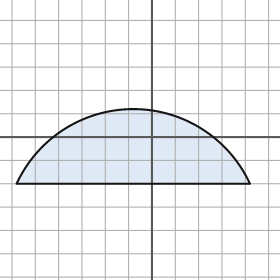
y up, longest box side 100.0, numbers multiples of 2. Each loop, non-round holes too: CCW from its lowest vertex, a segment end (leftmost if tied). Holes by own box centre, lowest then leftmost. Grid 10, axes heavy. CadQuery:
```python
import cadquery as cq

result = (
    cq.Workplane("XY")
    .moveTo(-58.0, -20.0)
    .lineTo(42.0, -20.0)
    .threePointArc((-8.0, 12.0), (-58.0, -20.0))
    .close()
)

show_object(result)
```